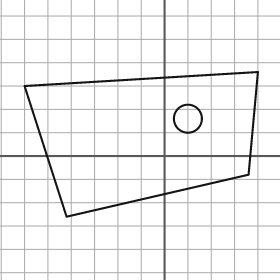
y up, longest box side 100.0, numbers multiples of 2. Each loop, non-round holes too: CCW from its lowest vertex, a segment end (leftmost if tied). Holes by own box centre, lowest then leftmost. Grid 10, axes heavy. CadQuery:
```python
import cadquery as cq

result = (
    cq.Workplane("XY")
    .moveTo(-42.0, -26.0)
    .lineTo(36.0, -8.0)
    .lineTo(40.0, 36.0)
    .lineTo(-60.0, 30.0)
    .close()
    .moveTo(10.0, 16.0)
    .circle(6.0)
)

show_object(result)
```